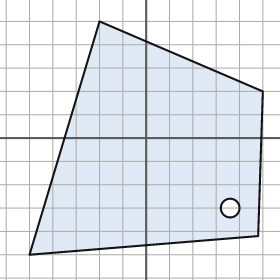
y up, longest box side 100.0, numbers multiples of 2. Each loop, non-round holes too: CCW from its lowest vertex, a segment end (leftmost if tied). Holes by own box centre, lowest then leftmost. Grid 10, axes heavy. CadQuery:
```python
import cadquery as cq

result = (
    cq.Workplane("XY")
    .moveTo(-50.0, -50.0)
    .lineTo(48.0, -42.0)
    .lineTo(50.0, 20.0)
    .lineTo(-20.0, 50.0)
    .close()
    .moveTo(36.0, -30.0)
    .circle(4.0)
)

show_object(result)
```